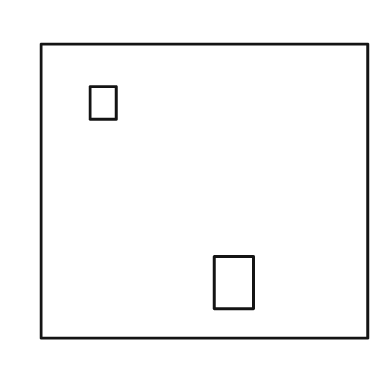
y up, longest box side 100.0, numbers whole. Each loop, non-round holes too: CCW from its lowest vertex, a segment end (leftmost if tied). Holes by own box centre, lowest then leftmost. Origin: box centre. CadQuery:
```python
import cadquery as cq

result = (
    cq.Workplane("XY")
    .moveTo(-50.0, -45.0)
    .lineTo(50.0, -45.0)
    .lineTo(50.0, 45.0)
    .lineTo(-50.0, 45.0)
    .close()
    .moveTo(3.0, -36.0)
    .lineTo(15.0, -36.0)
    .lineTo(15.0, -20.0)
    .lineTo(3.0, -20.0)
    .close()
    .moveTo(-35.0, 22.0)
    .lineTo(-27.0, 22.0)
    .lineTo(-27.0, 32.0)
    .lineTo(-35.0, 32.0)
    .close()
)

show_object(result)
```